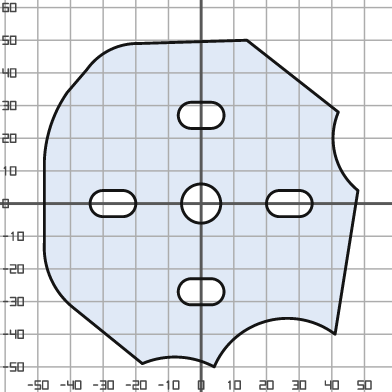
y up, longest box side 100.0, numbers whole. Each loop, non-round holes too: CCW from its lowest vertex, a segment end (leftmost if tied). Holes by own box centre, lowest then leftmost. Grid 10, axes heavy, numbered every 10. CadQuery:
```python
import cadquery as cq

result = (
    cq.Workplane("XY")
    .moveTo(4.0, -50.0)
    .threePointArc((20.0, -36.0), (41.0, -40.0))
    .lineTo(48.0, 4.0)
    .threePointArc((41.0, 15.0), (42.0, 28.0))
    .lineTo(14.0, 50.0)
    .lineTo(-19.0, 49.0)
    .threePointArc((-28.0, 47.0), (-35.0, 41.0))
    .lineTo(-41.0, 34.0)
    .threePointArc((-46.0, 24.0), (-48.0, 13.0))
    .lineTo(-48.0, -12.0)
    .threePointArc((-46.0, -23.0), (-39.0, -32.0))
    .lineTo(-18.0, -49.0)
    .threePointArc((-7.0, -47.0), (4.0, -50.0))
    .close()
    .moveTo(-3.0, -31.0)
    .lineTo(3.0, -31.0)
    .threePointArc((7.0, -27.0), (3.0, -23.0))
    .lineTo(-3.0, -23.0)
    .threePointArc((-7.0, -27.0), (-3.0, -31.0))
    .close()
    .moveTo(-30.0, -4.0)
    .lineTo(-24.0, -4.0)
    .threePointArc((-20.0, 0.0), (-24.0, 4.0))
    .lineTo(-30.0, 4.0)
    .threePointArc((-34.0, 0.0), (-30.0, -4.0))
    .close()
    .moveTo(0.0, 0.0)
    .circle(6.0)
    .moveTo(24.0, -4.0)
    .lineTo(30.0, -4.0)
    .threePointArc((34.0, 0.0), (30.0, 4.0))
    .lineTo(24.0, 4.0)
    .threePointArc((20.0, 0.0), (24.0, -4.0))
    .close()
    .moveTo(-3.0, 23.0)
    .lineTo(3.0, 23.0)
    .threePointArc((7.0, 27.0), (3.0, 31.0))
    .lineTo(-3.0, 31.0)
    .threePointArc((-7.0, 27.0), (-3.0, 23.0))
    .close()
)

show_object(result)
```